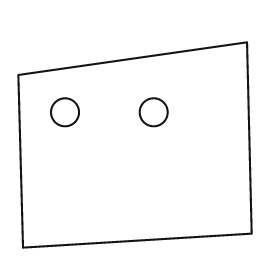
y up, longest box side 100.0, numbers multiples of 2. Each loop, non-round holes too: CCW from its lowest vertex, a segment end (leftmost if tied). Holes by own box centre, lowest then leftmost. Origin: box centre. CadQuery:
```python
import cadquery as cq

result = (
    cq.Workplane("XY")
    .moveTo(-48.0, -44.0)
    .lineTo(50.0, -38.0)
    .lineTo(48.0, 44.0)
    .lineTo(-50.0, 30.0)
    .close()
    .moveTo(-30.0, 14.0)
    .circle(6.0)
    .moveTo(8.0, 14.0)
    .circle(6.0)
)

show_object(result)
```